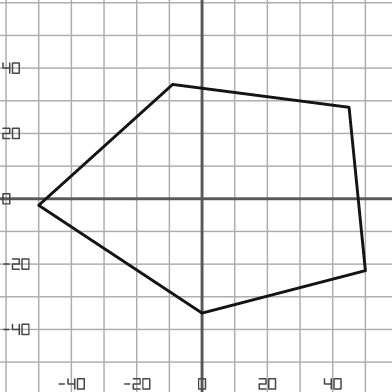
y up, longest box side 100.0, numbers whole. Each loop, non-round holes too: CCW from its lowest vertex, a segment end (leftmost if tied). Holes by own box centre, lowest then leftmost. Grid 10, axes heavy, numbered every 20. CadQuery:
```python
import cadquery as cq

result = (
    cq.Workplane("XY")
    .moveTo(0.0, -35.0)
    .lineTo(50.0, -22.0)
    .lineTo(45.0, 28.0)
    .lineTo(-9.0, 35.0)
    .lineTo(-50.0, -2.0)
    .close()
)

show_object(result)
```